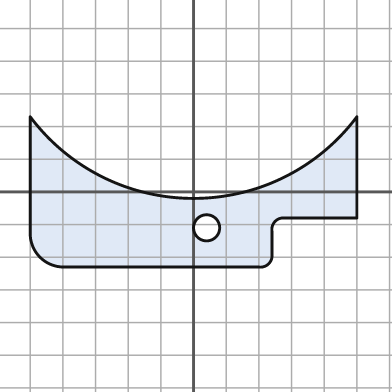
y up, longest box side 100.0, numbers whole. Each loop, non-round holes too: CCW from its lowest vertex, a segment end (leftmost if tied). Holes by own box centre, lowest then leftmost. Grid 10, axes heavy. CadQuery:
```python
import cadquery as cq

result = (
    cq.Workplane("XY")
    .moveTo(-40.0, -23.0)
    .lineTo(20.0, -23.0)
    .threePointArc((23.0, -22.0), (24.0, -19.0))
    .lineTo(24.0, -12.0)
    .threePointArc((25.0, -9.0), (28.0, -8.0))
    .lineTo(50.0, -8.0)
    .lineTo(50.0, 23.0)
    .threePointArc((0.0, -2.0), (-50.0, 23.0))
    .lineTo(-50.0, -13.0)
    .threePointArc((-47.0, -20.0), (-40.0, -23.0))
    .close()
    .moveTo(4.0, -11.0)
    .circle(4.0)
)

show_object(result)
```